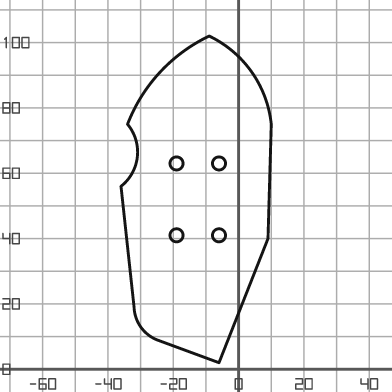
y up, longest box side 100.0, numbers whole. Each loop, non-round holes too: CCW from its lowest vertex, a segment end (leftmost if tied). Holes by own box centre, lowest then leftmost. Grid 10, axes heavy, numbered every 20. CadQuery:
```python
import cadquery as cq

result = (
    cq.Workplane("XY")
    .moveTo(-6.0, 2.0)
    .lineTo(9.0, 40.0)
    .lineTo(10.0, 75.0)
    .threePointArc((4.0, 91.0), (-9.0, 102.0))
    .threePointArc((-24.0, 91.0), (-34.0, 75.0))
    .threePointArc((-31.0, 65.0), (-36.0, 56.0))
    .lineTo(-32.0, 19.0)
    .threePointArc((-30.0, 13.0), (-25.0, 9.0))
    .close()
    .moveTo(-19.0, 41.0)
    .circle(2.0)
    .moveTo(-6.0, 41.0)
    .circle(2.0)
    .moveTo(-19.0, 63.0)
    .circle(2.0)
    .moveTo(-6.0, 63.0)
    .circle(2.0)
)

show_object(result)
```